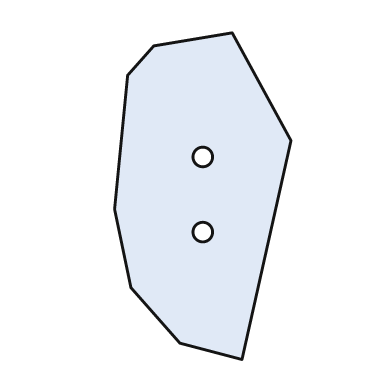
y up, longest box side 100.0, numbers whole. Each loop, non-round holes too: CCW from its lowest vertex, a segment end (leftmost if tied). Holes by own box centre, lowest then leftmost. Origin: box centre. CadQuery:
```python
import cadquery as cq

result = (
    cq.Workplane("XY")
    .moveTo(12.0, -50.0)
    .lineTo(27.0, 17.0)
    .lineTo(9.0, 50.0)
    .lineTo(-15.0, 46.0)
    .lineTo(-23.0, 37.0)
    .lineTo(-27.0, -4.0)
    .lineTo(-22.0, -28.0)
    .lineTo(-7.0, -45.0)
    .close()
    .moveTo(0.0, -11.0)
    .circle(3.0)
    .moveTo(0.0, 12.0)
    .circle(3.0)
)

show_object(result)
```